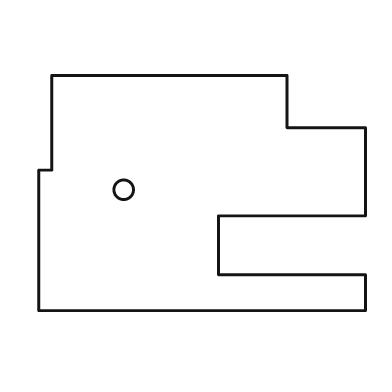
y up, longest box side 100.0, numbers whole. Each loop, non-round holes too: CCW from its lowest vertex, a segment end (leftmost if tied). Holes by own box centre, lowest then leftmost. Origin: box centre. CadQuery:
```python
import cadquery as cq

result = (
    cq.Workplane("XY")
    .moveTo(-50.0, -36.0)
    .lineTo(50.0, -36.0)
    .lineTo(50.0, -25.0)
    .lineTo(5.0, -25.0)
    .lineTo(5.0, -7.0)
    .lineTo(50.0, -7.0)
    .lineTo(50.0, 20.0)
    .lineTo(26.0, 20.0)
    .lineTo(26.0, 36.0)
    .lineTo(-46.0, 36.0)
    .lineTo(-46.0, 7.0)
    .lineTo(-50.0, 7.0)
    .close()
    .moveTo(-24.0, 1.0)
    .circle(3.0)
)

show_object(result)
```